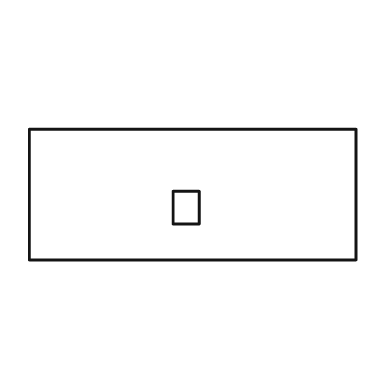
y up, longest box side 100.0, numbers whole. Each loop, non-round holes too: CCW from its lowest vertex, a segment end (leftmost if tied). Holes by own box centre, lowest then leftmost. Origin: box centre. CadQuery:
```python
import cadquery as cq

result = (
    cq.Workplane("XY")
    .moveTo(-50.0, -20.0)
    .lineTo(50.0, -20.0)
    .lineTo(50.0, 20.0)
    .lineTo(-50.0, 20.0)
    .close()
    .moveTo(-6.0, -9.0)
    .lineTo(2.0, -9.0)
    .lineTo(2.0, 1.0)
    .lineTo(-6.0, 1.0)
    .close()
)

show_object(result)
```